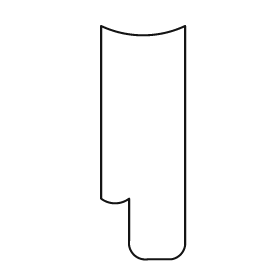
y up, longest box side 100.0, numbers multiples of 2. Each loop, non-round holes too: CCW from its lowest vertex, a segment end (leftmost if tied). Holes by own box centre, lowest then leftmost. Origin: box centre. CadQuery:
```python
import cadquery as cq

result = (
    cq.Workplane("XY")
    .moveTo(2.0, -50.0)
    .lineTo(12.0, -50.0)
    .threePointArc((16.0, -48.0), (18.0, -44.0))
    .lineTo(18.0, 50.0)
    .threePointArc((0.0, 46.0), (-18.0, 50.0))
    .lineTo(-18.0, -24.0)
    .threePointArc((-12.0, -26.0), (-6.0, -24.0))
    .lineTo(-6.0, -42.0)
    .threePointArc((-4.0, -48.0), (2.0, -50.0))
    .close()
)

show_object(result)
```